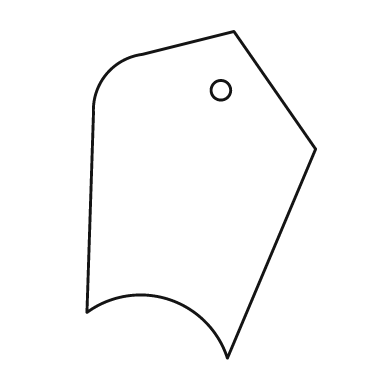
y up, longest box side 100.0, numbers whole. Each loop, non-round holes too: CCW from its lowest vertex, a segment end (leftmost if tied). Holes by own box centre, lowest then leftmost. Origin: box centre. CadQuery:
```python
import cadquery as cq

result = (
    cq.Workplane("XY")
    .moveTo(8.0, -50.0)
    .lineTo(35.0, 14.0)
    .lineTo(10.0, 50.0)
    .lineTo(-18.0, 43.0)
    .threePointArc((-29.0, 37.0), (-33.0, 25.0))
    .lineTo(-35.0, -36.0)
    .threePointArc((-10.0, -32.0), (8.0, -50.0))
    .close()
    .moveTo(6.0, 32.0)
    .circle(3.0)
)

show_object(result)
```